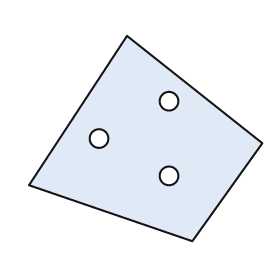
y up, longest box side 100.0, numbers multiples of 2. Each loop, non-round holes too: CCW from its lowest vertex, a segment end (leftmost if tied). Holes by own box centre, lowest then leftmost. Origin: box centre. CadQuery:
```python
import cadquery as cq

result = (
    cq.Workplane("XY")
    .moveTo(20.0, -44.0)
    .lineTo(50.0, -2.0)
    .lineTo(-8.0, 44.0)
    .lineTo(-50.0, -20.0)
    .close()
    .moveTo(10.0, -16.0)
    .circle(4.0)
    .moveTo(-20.0, 0.0)
    .circle(4.0)
    .moveTo(10.0, 16.0)
    .circle(4.0)
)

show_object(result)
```